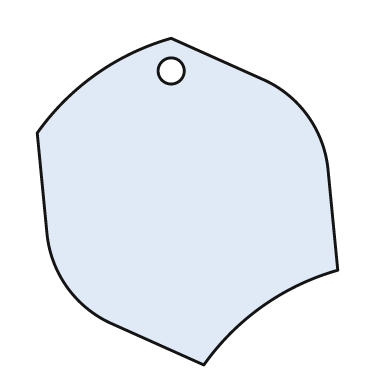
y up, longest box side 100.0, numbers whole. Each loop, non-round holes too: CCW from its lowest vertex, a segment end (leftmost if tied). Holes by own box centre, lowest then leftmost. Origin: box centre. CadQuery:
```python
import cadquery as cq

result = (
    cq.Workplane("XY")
    .moveTo(5.0, -50.0)
    .threePointArc((23.0, -32.0), (46.0, -21.0))
    .lineTo(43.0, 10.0)
    .threePointArc((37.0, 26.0), (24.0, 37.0))
    .lineTo(-5.0, 50.0)
    .threePointArc((-28.0, 39.0), (-46.0, 21.0))
    .lineTo(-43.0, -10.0)
    .threePointArc((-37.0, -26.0), (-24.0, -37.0))
    .close()
    .moveTo(-5.0, 40.0)
    .circle(4.0)
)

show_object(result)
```